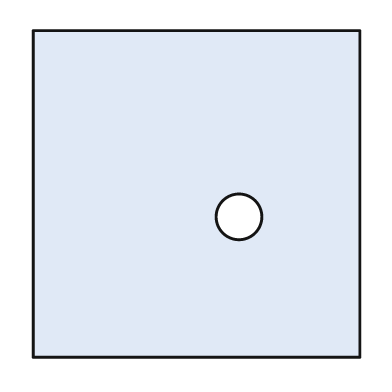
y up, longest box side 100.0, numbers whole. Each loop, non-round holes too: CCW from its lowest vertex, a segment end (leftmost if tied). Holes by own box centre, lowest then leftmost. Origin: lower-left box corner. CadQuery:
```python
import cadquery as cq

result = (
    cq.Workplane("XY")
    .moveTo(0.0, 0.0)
    .lineTo(100.0, 0.0)
    .lineTo(100.0, 100.0)
    .lineTo(0.0, 100.0)
    .close()
    .moveTo(63.0, 43.0)
    .circle(7.0)
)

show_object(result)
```